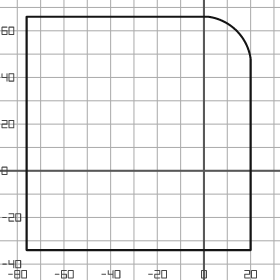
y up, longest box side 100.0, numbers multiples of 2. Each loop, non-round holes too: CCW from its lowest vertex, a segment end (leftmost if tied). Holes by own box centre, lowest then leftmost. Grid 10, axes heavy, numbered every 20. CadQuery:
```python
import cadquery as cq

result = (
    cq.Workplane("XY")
    .moveTo(-76.0, -34.0)
    .lineTo(20.0, -34.0)
    .lineTo(20.0, 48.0)
    .threePointArc((14.0, 60.0), (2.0, 66.0))
    .lineTo(-76.0, 66.0)
    .close()
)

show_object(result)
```